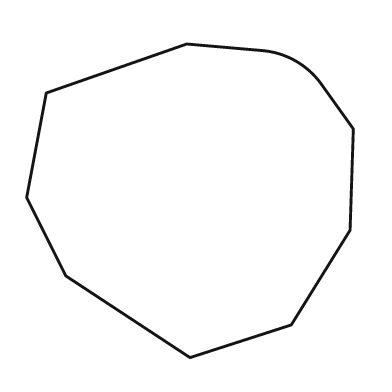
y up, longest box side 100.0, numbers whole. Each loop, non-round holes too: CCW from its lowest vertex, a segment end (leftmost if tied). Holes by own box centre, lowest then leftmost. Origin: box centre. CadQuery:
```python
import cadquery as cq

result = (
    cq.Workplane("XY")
    .moveTo(0.0, -48.0)
    .lineTo(31.0, -38.0)
    .lineTo(49.0, -9.0)
    .lineTo(50.0, 22.0)
    .lineTo(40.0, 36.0)
    .threePointArc((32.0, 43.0), (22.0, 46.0))
    .lineTo(-1.0, 48.0)
    .lineTo(-44.0, 33.0)
    .lineTo(-50.0, 1.0)
    .lineTo(-38.0, -23.0)
    .close()
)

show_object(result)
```